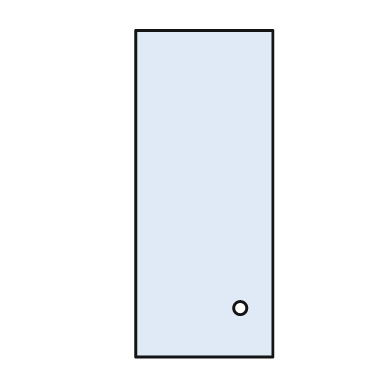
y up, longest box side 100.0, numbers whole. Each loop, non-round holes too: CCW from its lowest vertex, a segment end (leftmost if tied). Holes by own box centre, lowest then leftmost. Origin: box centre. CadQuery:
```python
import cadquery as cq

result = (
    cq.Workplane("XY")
    .moveTo(-21.0, -50.0)
    .lineTo(21.0, -50.0)
    .lineTo(21.0, 50.0)
    .lineTo(-21.0, 50.0)
    .close()
    .moveTo(11.0, -35.0)
    .circle(2.0)
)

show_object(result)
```